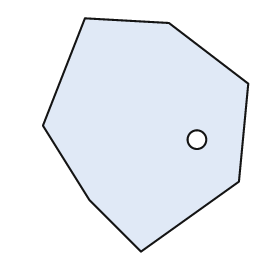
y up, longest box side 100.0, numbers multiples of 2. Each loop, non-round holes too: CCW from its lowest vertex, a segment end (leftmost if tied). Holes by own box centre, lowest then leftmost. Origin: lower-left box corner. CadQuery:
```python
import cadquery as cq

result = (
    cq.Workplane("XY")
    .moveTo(42.0, 0.0)
    .lineTo(84.0, 30.0)
    .lineTo(88.0, 72.0)
    .lineTo(54.0, 98.0)
    .lineTo(18.0, 100.0)
    .lineTo(0.0, 54.0)
    .lineTo(20.0, 22.0)
    .close()
    .moveTo(66.0, 48.0)
    .circle(4.0)
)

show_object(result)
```